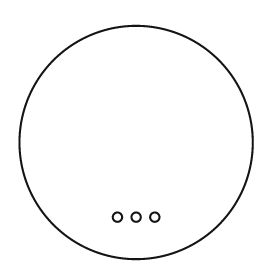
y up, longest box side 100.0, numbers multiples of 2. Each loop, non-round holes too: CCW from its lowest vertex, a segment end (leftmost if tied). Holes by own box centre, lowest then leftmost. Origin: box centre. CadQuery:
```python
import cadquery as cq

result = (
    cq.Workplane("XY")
    .moveTo(0.0, 0.0)
    .circle(50.0)
    .moveTo(-8.0, -32.0)
    .circle(2.0)
    .moveTo(0.0, -32.0)
    .circle(2.0)
    .moveTo(8.0, -32.0)
    .circle(2.0)
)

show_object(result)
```